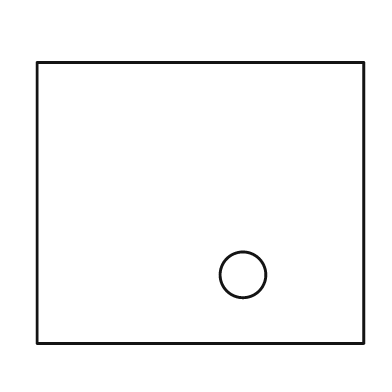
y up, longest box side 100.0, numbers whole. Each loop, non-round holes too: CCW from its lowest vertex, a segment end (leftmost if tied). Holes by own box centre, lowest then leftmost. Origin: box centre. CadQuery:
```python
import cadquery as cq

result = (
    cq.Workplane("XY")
    .moveTo(-50.0, -43.0)
    .lineTo(50.0, -43.0)
    .lineTo(50.0, 43.0)
    .lineTo(-50.0, 43.0)
    .close()
    .moveTo(13.0, -22.0)
    .circle(7.0)
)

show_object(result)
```